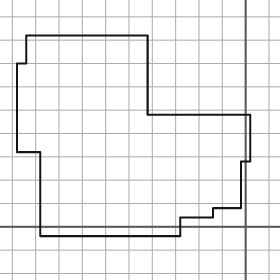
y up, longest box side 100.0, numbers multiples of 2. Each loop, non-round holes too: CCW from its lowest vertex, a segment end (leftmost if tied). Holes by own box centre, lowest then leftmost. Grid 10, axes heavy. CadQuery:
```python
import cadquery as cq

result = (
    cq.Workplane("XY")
    .moveTo(-88.0, -4.0)
    .lineTo(-28.0, -4.0)
    .lineTo(-28.0, 4.0)
    .lineTo(-14.0, 4.0)
    .lineTo(-14.0, 8.0)
    .lineTo(-2.0, 8.0)
    .lineTo(-2.0, 28.0)
    .lineTo(2.0, 28.0)
    .lineTo(2.0, 48.0)
    .lineTo(-42.0, 48.0)
    .lineTo(-42.0, 82.0)
    .lineTo(-94.0, 82.0)
    .lineTo(-94.0, 70.0)
    .lineTo(-98.0, 70.0)
    .lineTo(-98.0, 32.0)
    .lineTo(-88.0, 32.0)
    .close()
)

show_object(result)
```